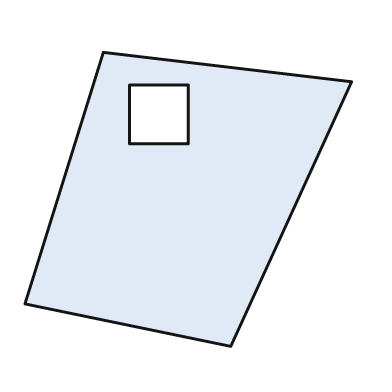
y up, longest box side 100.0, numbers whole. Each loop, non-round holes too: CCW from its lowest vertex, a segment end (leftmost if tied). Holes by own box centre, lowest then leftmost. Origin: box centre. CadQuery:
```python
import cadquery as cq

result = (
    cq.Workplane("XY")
    .moveTo(13.0, -45.0)
    .lineTo(50.0, 36.0)
    .lineTo(-26.0, 45.0)
    .lineTo(-50.0, -32.0)
    .close()
    .moveTo(-18.0, 17.0)
    .lineTo(0.0, 17.0)
    .lineTo(0.0, 35.0)
    .lineTo(-18.0, 35.0)
    .close()
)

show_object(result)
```